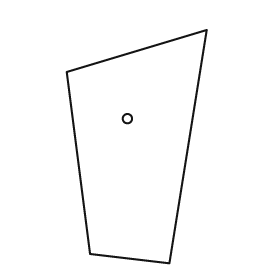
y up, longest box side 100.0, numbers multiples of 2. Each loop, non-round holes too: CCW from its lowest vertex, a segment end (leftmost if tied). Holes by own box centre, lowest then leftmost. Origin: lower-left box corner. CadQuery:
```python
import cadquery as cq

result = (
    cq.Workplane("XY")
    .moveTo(44.0, 0.0)
    .lineTo(60.0, 100.0)
    .lineTo(0.0, 82.0)
    .lineTo(10.0, 4.0)
    .close()
    .moveTo(26.0, 62.0)
    .circle(2.0)
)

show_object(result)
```